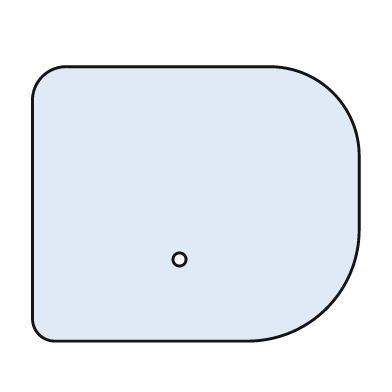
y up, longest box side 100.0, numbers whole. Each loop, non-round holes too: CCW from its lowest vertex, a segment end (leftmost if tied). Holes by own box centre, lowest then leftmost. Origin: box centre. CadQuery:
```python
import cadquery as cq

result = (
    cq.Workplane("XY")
    .moveTo(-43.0, -42.0)
    .lineTo(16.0, -42.0)
    .threePointArc((40.0, -32.0), (50.0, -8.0))
    .lineTo(50.0, 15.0)
    .threePointArc((42.0, 34.0), (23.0, 42.0))
    .lineTo(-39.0, 42.0)
    .threePointArc((-47.0, 39.0), (-50.0, 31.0))
    .lineTo(-50.0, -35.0)
    .threePointArc((-48.0, -40.0), (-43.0, -42.0))
    .close()
    .moveTo(-5.0, -17.0)
    .circle(2.0)
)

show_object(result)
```